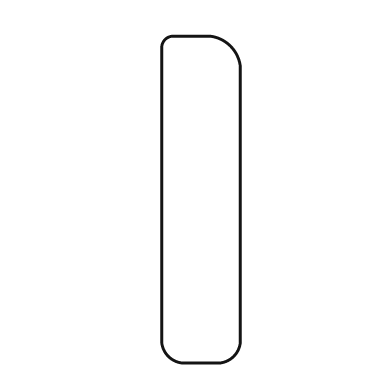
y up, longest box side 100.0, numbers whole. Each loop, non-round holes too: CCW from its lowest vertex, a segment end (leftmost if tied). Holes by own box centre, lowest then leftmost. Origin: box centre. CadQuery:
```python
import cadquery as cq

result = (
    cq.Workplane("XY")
    .moveTo(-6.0, -50.0)
    .lineTo(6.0, -50.0)
    .threePointArc((10.0, -48.0), (12.0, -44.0))
    .lineTo(12.0, 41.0)
    .threePointArc((9.0, 47.0), (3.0, 50.0))
    .lineTo(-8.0, 50.0)
    .threePointArc((-11.0, 49.0), (-12.0, 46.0))
    .lineTo(-12.0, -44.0)
    .threePointArc((-10.0, -48.0), (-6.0, -50.0))
    .close()
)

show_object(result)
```